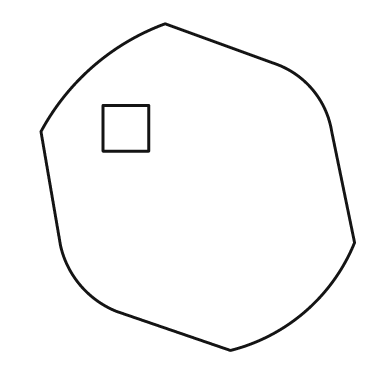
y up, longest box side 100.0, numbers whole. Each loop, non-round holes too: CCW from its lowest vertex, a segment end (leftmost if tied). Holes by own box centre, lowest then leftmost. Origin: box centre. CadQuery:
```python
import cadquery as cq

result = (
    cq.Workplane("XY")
    .moveTo(10.0, -50.0)
    .threePointArc((33.0, -38.0), (48.0, -17.0))
    .lineTo(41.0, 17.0)
    .threePointArc((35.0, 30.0), (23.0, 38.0))
    .lineTo(-10.0, 50.0)
    .threePointArc((-32.0, 37.0), (-48.0, 17.0))
    .lineTo(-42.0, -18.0)
    .threePointArc((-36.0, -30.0), (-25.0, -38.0))
    .close()
    .moveTo(-29.0, 11.0)
    .lineTo(-15.0, 11.0)
    .lineTo(-15.0, 25.0)
    .lineTo(-29.0, 25.0)
    .close()
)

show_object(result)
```